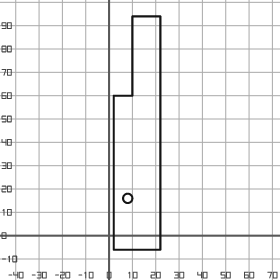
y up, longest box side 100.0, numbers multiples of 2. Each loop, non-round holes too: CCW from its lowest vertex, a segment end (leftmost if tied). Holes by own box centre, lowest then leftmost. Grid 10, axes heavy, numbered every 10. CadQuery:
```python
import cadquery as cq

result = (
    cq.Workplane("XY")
    .moveTo(2.0, -6.0)
    .lineTo(22.0, -6.0)
    .lineTo(22.0, 94.0)
    .lineTo(10.0, 94.0)
    .lineTo(10.0, 60.0)
    .lineTo(2.0, 60.0)
    .close()
    .moveTo(8.0, 16.0)
    .circle(2.0)
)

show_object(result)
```